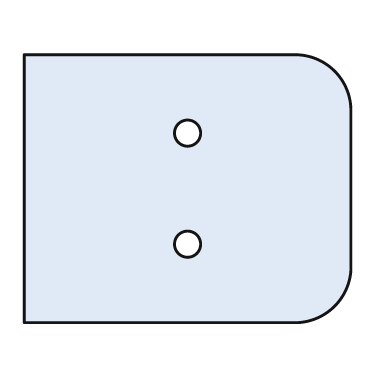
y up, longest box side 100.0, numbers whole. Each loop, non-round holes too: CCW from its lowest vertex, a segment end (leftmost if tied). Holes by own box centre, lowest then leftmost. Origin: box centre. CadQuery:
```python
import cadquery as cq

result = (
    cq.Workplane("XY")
    .moveTo(-50.0, -41.0)
    .lineTo(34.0, -41.0)
    .threePointArc((45.0, -36.0), (50.0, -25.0))
    .lineTo(50.0, 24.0)
    .threePointArc((45.0, 36.0), (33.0, 41.0))
    .lineTo(-50.0, 41.0)
    .close()
    .moveTo(0.0, -17.0)
    .circle(4.0)
    .moveTo(0.0, 17.0)
    .circle(4.0)
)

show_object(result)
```